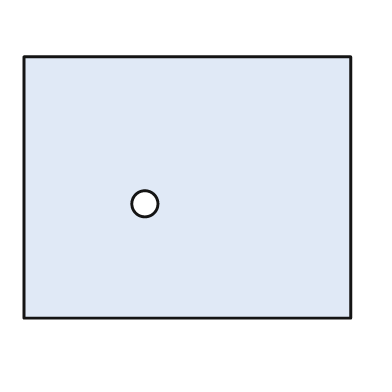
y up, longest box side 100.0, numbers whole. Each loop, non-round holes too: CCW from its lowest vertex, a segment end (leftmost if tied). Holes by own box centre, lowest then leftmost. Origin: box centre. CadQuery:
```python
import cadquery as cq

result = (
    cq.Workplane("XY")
    .moveTo(-50.0, -40.0)
    .lineTo(50.0, -40.0)
    .lineTo(50.0, 40.0)
    .lineTo(-50.0, 40.0)
    .close()
    .moveTo(-13.0, -5.0)
    .circle(4.0)
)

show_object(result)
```